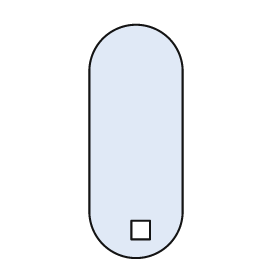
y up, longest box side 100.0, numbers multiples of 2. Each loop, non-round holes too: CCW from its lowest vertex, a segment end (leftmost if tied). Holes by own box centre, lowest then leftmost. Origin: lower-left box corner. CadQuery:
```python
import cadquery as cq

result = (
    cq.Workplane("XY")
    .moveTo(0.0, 20.0)
    .threePointArc((20.0, 0.0), (40.0, 20.0))
    .lineTo(40.0, 80.0)
    .threePointArc((20.0, 100.0), (0.0, 80.0))
    .close()
    .moveTo(18.0, 8.0)
    .lineTo(26.0, 8.0)
    .lineTo(26.0, 16.0)
    .lineTo(18.0, 16.0)
    .close()
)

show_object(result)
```